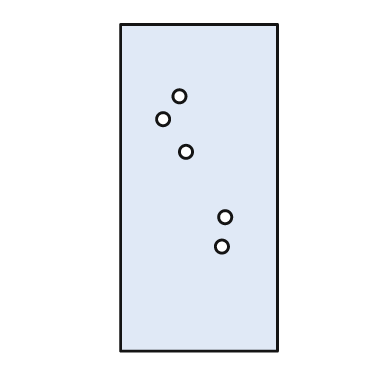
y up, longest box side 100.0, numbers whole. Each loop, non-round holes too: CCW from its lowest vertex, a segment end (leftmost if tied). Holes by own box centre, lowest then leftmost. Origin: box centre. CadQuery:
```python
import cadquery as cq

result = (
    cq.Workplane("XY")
    .moveTo(-24.0, -50.0)
    .lineTo(24.0, -50.0)
    .lineTo(24.0, 50.0)
    .lineTo(-24.0, 50.0)
    .close()
    .moveTo(7.0, -18.0)
    .circle(2.0)
    .moveTo(8.0, -9.0)
    .circle(2.0)
    .moveTo(-4.0, 11.0)
    .circle(2.0)
    .moveTo(-11.0, 21.0)
    .circle(2.0)
    .moveTo(-6.0, 28.0)
    .circle(2.0)
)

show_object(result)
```